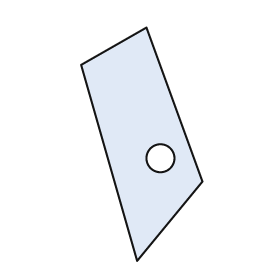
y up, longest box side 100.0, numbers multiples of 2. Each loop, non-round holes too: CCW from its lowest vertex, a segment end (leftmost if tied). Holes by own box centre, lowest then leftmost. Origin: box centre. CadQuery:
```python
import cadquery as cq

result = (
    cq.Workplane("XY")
    .moveTo(-2.0, -50.0)
    .lineTo(26.0, -16.0)
    .lineTo(2.0, 50.0)
    .lineTo(-26.0, 34.0)
    .close()
    .moveTo(8.0, -6.0)
    .circle(6.0)
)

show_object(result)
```